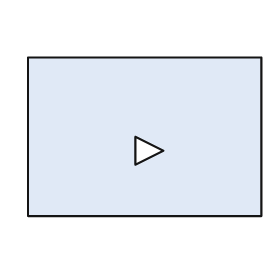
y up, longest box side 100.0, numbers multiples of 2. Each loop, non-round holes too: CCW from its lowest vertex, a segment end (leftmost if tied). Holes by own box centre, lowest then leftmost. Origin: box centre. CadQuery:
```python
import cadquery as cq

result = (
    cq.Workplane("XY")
    .moveTo(-50.0, -34.0)
    .lineTo(50.0, -34.0)
    .lineTo(50.0, 34.0)
    .lineTo(-50.0, 34.0)
    .close()
    .moveTo(-4.0, -12.0)
    .lineTo(8.0, -6.0)
    .lineTo(-4.0, 0.0)
    .close()
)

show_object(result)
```